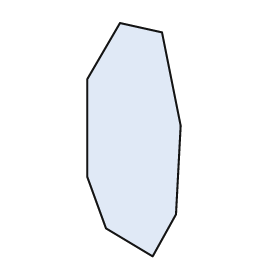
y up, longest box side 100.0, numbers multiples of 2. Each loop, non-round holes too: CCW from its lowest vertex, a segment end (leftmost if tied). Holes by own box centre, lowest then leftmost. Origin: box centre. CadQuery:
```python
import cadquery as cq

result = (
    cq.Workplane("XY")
    .moveTo(8.0, -50.0)
    .lineTo(18.0, -32.0)
    .lineTo(20.0, 6.0)
    .lineTo(12.0, 46.0)
    .lineTo(-6.0, 50.0)
    .lineTo(-20.0, 26.0)
    .lineTo(-20.0, -16.0)
    .lineTo(-12.0, -38.0)
    .close()
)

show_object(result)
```